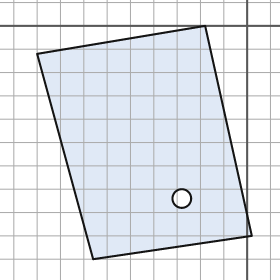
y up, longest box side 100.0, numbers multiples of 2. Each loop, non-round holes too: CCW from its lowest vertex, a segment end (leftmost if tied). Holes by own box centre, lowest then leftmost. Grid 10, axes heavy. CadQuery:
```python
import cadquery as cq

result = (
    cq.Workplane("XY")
    .moveTo(-66.0, -100.0)
    .lineTo(2.0, -90.0)
    .lineTo(-18.0, 0.0)
    .lineTo(-90.0, -12.0)
    .close()
    .moveTo(-28.0, -74.0)
    .circle(4.0)
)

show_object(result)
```